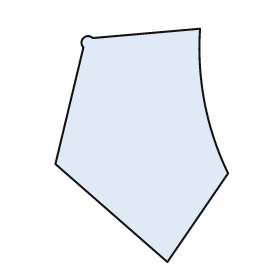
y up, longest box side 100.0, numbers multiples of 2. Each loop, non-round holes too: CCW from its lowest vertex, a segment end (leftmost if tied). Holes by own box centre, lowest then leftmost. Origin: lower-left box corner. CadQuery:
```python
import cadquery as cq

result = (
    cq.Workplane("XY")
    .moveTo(48.0, 0.0)
    .lineTo(74.0, 38.0)
    .threePointArc((64.0, 68.0), (62.0, 100.0))
    .lineTo(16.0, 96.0)
    .threePointArc((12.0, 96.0), (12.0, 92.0))
    .lineTo(0.0, 42.0)
    .close()
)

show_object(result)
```